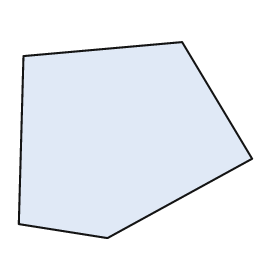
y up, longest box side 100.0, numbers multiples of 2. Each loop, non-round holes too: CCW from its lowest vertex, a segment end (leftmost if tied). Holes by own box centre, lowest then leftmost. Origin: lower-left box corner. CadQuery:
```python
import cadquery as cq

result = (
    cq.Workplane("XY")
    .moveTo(38.0, 0.0)
    .lineTo(100.0, 34.0)
    .lineTo(70.0, 84.0)
    .lineTo(2.0, 78.0)
    .lineTo(0.0, 6.0)
    .close()
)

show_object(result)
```